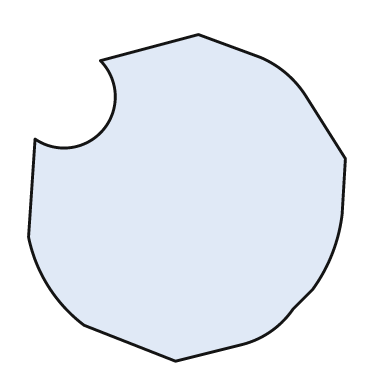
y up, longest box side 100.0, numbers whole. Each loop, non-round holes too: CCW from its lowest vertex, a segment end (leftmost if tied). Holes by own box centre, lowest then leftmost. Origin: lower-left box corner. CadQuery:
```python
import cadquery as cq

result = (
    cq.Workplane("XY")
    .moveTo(45.0, 0.0)
    .lineTo(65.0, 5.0)
    .threePointArc((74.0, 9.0), (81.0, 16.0))
    .lineTo(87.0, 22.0)
    .threePointArc((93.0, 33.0), (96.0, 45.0))
    .lineTo(97.0, 62.0)
    .lineTo(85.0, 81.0)
    .threePointArc((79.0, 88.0), (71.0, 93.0))
    .lineTo(52.0, 100.0)
    .lineTo(22.0, 92.0)
    .threePointArc((23.0, 71.0), (2.0, 68.0))
    .lineTo(0.0, 38.0)
    .threePointArc((6.0, 23.0), (17.0, 11.0))
    .close()
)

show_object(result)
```